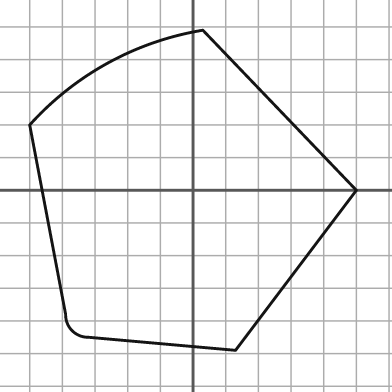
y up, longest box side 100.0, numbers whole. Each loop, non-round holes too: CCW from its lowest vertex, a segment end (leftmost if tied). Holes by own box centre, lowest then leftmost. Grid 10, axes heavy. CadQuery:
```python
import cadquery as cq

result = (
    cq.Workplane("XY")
    .moveTo(13.0, -49.0)
    .lineTo(50.0, 0.0)
    .lineTo(3.0, 49.0)
    .threePointArc((-26.0, 39.0), (-50.0, 20.0))
    .lineTo(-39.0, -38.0)
    .threePointArc((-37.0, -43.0), (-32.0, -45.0))
    .close()
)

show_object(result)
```